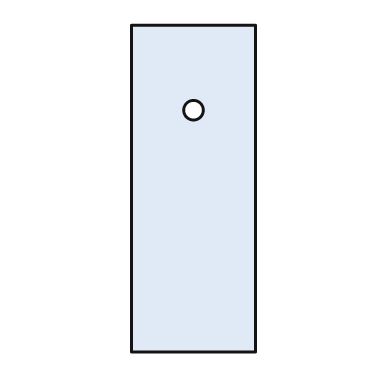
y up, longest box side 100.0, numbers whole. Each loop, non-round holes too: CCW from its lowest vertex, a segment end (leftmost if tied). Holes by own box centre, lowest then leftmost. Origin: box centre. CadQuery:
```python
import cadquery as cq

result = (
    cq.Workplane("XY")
    .moveTo(-19.0, -50.0)
    .lineTo(19.0, -50.0)
    .lineTo(19.0, 50.0)
    .lineTo(-19.0, 50.0)
    .close()
    .moveTo(0.0, 24.0)
    .circle(3.0)
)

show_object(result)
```